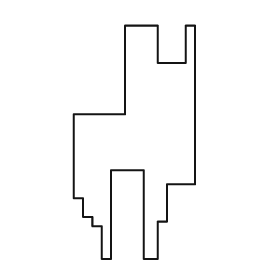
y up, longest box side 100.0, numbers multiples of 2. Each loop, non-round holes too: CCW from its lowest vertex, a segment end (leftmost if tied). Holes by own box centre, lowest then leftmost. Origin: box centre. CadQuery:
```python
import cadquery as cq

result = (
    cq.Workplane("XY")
    .moveTo(-14.0, -50.0)
    .lineTo(-10.0, -50.0)
    .lineTo(-10.0, -12.0)
    .lineTo(4.0, -12.0)
    .lineTo(4.0, -50.0)
    .lineTo(10.0, -50.0)
    .lineTo(10.0, -34.0)
    .lineTo(14.0, -34.0)
    .lineTo(14.0, -18.0)
    .lineTo(26.0, -18.0)
    .lineTo(26.0, 50.0)
    .lineTo(22.0, 50.0)
    .lineTo(22.0, 34.0)
    .lineTo(10.0, 34.0)
    .lineTo(10.0, 50.0)
    .lineTo(-4.0, 50.0)
    .lineTo(-4.0, 12.0)
    .lineTo(-26.0, 12.0)
    .lineTo(-26.0, -24.0)
    .lineTo(-22.0, -24.0)
    .lineTo(-22.0, -32.0)
    .lineTo(-18.0, -32.0)
    .lineTo(-18.0, -36.0)
    .lineTo(-14.0, -36.0)
    .close()
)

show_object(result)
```